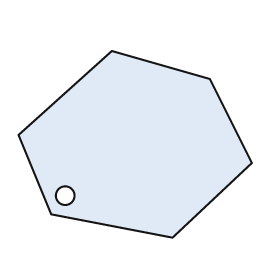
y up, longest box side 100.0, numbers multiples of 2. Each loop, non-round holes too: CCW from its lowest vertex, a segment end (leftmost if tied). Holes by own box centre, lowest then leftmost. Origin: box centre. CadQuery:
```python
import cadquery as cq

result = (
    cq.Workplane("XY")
    .moveTo(16.0, -40.0)
    .lineTo(50.0, -8.0)
    .lineTo(32.0, 28.0)
    .lineTo(-10.0, 40.0)
    .lineTo(-50.0, 4.0)
    .lineTo(-36.0, -30.0)
    .close()
    .moveTo(-30.0, -22.0)
    .circle(4.0)
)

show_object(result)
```